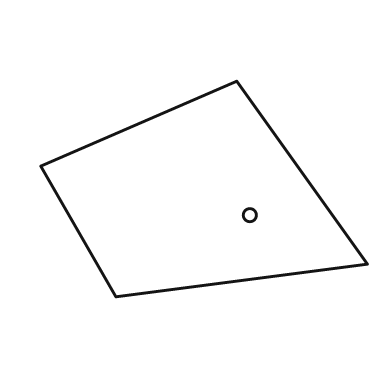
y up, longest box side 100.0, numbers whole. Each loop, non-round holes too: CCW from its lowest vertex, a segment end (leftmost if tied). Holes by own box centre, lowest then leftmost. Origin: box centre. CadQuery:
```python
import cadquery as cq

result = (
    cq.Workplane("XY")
    .moveTo(-27.0, -33.0)
    .lineTo(50.0, -23.0)
    .lineTo(10.0, 33.0)
    .lineTo(-50.0, 7.0)
    .close()
    .moveTo(14.0, -8.0)
    .circle(2.0)
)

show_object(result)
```